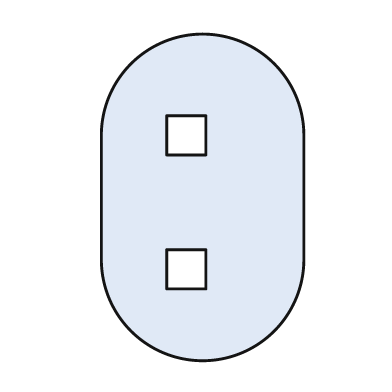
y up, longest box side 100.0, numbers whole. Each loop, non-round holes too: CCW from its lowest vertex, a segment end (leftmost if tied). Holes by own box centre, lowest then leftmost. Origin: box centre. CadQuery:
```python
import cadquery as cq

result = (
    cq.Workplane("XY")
    .moveTo(-31.0, -19.0)
    .threePointArc((0.0, -50.0), (31.0, -19.0))
    .lineTo(31.0, 19.0)
    .threePointArc((0.0, 50.0), (-31.0, 19.0))
    .close()
    .moveTo(-11.0, -28.0)
    .lineTo(1.0, -28.0)
    .lineTo(1.0, -16.0)
    .lineTo(-11.0, -16.0)
    .close()
    .moveTo(-11.0, 13.0)
    .lineTo(1.0, 13.0)
    .lineTo(1.0, 25.0)
    .lineTo(-11.0, 25.0)
    .close()
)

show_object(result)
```